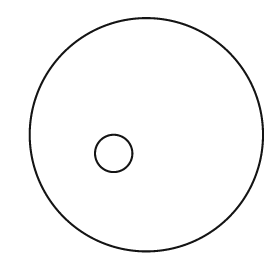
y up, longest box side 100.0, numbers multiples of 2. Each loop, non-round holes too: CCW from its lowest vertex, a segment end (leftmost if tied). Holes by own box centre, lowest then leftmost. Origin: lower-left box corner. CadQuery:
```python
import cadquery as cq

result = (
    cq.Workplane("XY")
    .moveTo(50.0, 50.0)
    .circle(50.0)
    .moveTo(36.0, 42.0)
    .circle(8.0)
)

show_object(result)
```